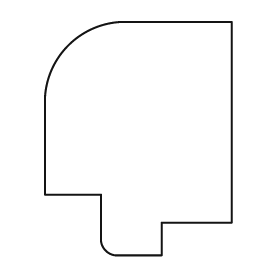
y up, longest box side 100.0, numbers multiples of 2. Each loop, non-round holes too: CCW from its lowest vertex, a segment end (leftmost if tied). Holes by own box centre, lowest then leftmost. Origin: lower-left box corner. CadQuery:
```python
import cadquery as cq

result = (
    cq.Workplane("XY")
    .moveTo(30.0, 0.0)
    .lineTo(50.0, 0.0)
    .lineTo(50.0, 14.0)
    .lineTo(80.0, 14.0)
    .lineTo(80.0, 100.0)
    .lineTo(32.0, 100.0)
    .threePointArc((10.0, 90.0), (0.0, 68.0))
    .lineTo(0.0, 26.0)
    .lineTo(24.0, 26.0)
    .lineTo(24.0, 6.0)
    .threePointArc((26.0, 2.0), (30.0, 0.0))
    .close()
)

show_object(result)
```